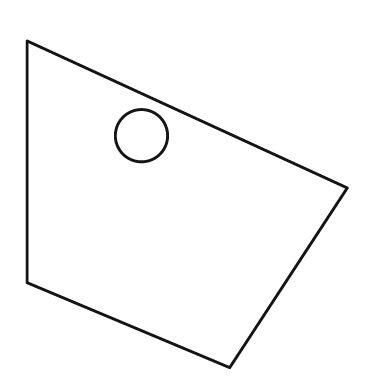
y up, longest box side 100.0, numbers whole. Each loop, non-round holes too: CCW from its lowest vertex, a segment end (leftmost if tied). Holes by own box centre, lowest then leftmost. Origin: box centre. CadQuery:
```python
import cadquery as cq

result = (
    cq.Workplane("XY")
    .moveTo(13.0, -50.0)
    .lineTo(49.0, 5.0)
    .lineTo(-49.0, 50.0)
    .lineTo(-49.0, -24.0)
    .close()
    .moveTo(-14.0, 21.0)
    .circle(8.0)
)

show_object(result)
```